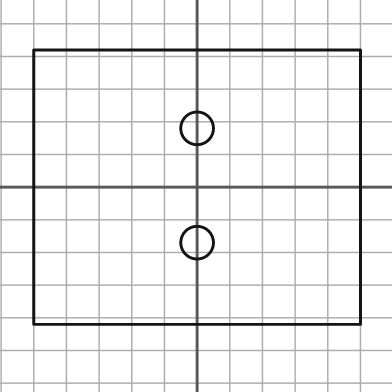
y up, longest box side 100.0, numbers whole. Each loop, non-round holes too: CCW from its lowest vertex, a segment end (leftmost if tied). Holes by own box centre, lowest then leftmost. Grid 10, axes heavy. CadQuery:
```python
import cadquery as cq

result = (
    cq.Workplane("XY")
    .moveTo(-50.0, -42.0)
    .lineTo(50.0, -42.0)
    .lineTo(50.0, 42.0)
    .lineTo(-50.0, 42.0)
    .close()
    .moveTo(0.0, -17.0)
    .circle(5.0)
    .moveTo(0.0, 18.0)
    .circle(5.0)
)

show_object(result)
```